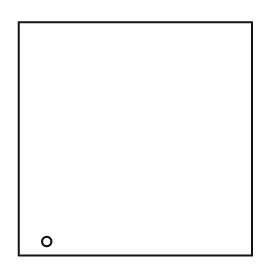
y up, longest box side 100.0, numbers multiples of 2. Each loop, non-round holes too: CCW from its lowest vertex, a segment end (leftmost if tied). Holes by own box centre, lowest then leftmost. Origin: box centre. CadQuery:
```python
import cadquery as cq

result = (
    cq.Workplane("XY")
    .moveTo(-50.0, -50.0)
    .lineTo(50.0, -50.0)
    .lineTo(50.0, 50.0)
    .lineTo(-50.0, 50.0)
    .close()
    .moveTo(-38.0, -44.0)
    .circle(2.0)
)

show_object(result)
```